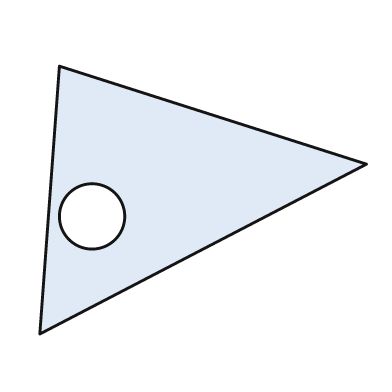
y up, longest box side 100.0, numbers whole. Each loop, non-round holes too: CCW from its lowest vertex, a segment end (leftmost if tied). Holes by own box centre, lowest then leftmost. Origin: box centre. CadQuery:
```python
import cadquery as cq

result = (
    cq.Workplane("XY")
    .moveTo(-50.0, -41.0)
    .lineTo(50.0, 11.0)
    .lineTo(-44.0, 41.0)
    .close()
    .moveTo(-34.0, -5.0)
    .circle(10.0)
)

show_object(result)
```